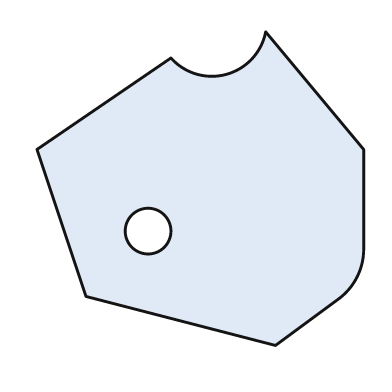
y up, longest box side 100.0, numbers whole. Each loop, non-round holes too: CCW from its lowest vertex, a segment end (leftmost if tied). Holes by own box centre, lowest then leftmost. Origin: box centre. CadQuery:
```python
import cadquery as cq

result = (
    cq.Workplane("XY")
    .moveTo(23.0, -48.0)
    .lineTo(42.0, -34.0)
    .threePointArc((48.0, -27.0), (50.0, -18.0))
    .lineTo(50.0, 12.0)
    .lineTo(20.0, 48.0)
    .threePointArc((8.0, 35.0), (-9.0, 40.0))
    .lineTo(-50.0, 12.0)
    .lineTo(-35.0, -33.0)
    .close()
    .moveTo(-16.0, -13.0)
    .circle(7.0)
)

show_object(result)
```